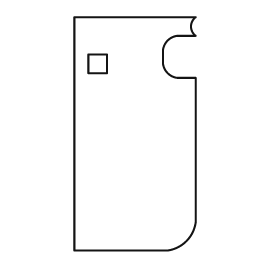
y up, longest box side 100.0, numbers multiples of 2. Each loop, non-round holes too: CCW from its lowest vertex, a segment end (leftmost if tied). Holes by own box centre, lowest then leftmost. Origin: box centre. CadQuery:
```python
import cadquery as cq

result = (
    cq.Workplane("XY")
    .moveTo(-26.0, -50.0)
    .lineTo(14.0, -50.0)
    .threePointArc((22.0, -46.0), (26.0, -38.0))
    .lineTo(26.0, 24.0)
    .lineTo(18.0, 24.0)
    .threePointArc((14.0, 26.0), (12.0, 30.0))
    .lineTo(12.0, 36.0)
    .threePointArc((14.0, 40.0), (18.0, 42.0))
    .lineTo(26.0, 42.0)
    .threePointArc((24.0, 46.0), (26.0, 50.0))
    .lineTo(-26.0, 50.0)
    .close()
    .moveTo(-20.0, 26.0)
    .lineTo(-12.0, 26.0)
    .lineTo(-12.0, 34.0)
    .lineTo(-20.0, 34.0)
    .close()
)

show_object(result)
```